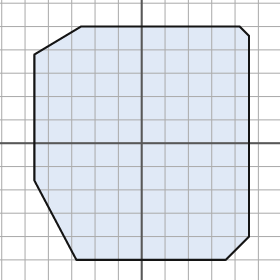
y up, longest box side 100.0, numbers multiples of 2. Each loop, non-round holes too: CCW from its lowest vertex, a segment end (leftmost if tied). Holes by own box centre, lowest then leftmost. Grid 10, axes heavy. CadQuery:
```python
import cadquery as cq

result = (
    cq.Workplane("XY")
    .moveTo(-28.0, -50.0)
    .lineTo(36.0, -50.0)
    .lineTo(46.0, -40.0)
    .lineTo(46.0, 46.0)
    .lineTo(42.0, 50.0)
    .lineTo(-26.0, 50.0)
    .lineTo(-46.0, 38.0)
    .lineTo(-46.0, -16.0)
    .close()
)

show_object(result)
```